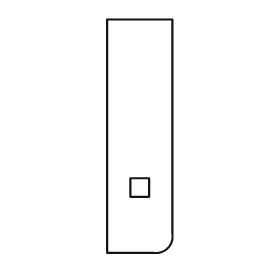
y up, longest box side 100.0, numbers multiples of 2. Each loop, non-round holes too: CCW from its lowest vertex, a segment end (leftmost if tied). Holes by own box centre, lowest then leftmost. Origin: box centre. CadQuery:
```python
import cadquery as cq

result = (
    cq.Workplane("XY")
    .moveTo(-14.0, -50.0)
    .lineTo(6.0, -50.0)
    .threePointArc((12.0, -48.0), (14.0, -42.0))
    .lineTo(14.0, 50.0)
    .lineTo(-14.0, 50.0)
    .close()
    .moveTo(-4.0, -26.0)
    .lineTo(4.0, -26.0)
    .lineTo(4.0, -18.0)
    .lineTo(-4.0, -18.0)
    .close()
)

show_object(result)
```